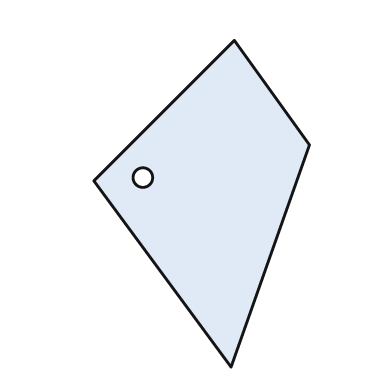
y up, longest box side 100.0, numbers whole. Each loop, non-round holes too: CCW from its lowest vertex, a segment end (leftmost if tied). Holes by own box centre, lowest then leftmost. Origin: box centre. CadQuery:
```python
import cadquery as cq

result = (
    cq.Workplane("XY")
    .moveTo(9.0, -50.0)
    .lineTo(33.0, 18.0)
    .lineTo(10.0, 50.0)
    .lineTo(-33.0, 7.0)
    .close()
    .moveTo(-18.0, 8.0)
    .circle(3.0)
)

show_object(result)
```